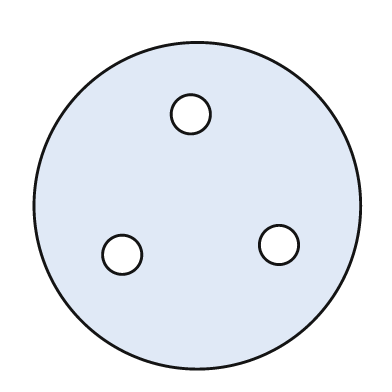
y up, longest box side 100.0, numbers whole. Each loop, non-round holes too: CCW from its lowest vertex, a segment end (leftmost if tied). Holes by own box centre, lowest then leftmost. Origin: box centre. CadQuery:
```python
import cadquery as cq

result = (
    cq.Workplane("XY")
    .moveTo(0.0, 0.0)
    .circle(50.0)
    .moveTo(-23.0, -15.0)
    .circle(6.0)
    .moveTo(25.0, -12.0)
    .circle(6.0)
    .moveTo(-2.0, 28.0)
    .circle(6.0)
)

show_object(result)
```